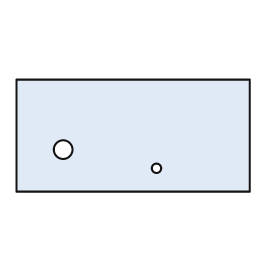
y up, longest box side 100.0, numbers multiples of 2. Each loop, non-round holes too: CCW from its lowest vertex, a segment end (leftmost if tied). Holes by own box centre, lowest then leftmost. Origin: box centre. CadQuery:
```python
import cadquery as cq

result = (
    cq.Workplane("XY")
    .moveTo(-50.0, -24.0)
    .lineTo(50.0, -24.0)
    .lineTo(50.0, 24.0)
    .lineTo(-50.0, 24.0)
    .close()
    .moveTo(10.0, -14.0)
    .circle(2.0)
    .moveTo(-30.0, -6.0)
    .circle(4.0)
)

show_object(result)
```